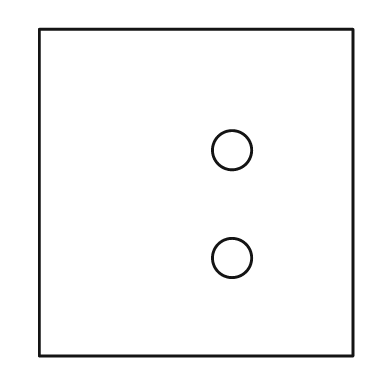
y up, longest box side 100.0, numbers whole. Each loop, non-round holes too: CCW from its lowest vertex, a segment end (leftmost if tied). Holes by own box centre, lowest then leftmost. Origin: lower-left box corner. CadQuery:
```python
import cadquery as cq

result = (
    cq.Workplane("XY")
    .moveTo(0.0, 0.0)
    .lineTo(96.0, 0.0)
    .lineTo(96.0, 100.0)
    .lineTo(0.0, 100.0)
    .close()
    .moveTo(59.0, 30.0)
    .circle(6.0)
    .moveTo(59.0, 63.0)
    .circle(6.0)
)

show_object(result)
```